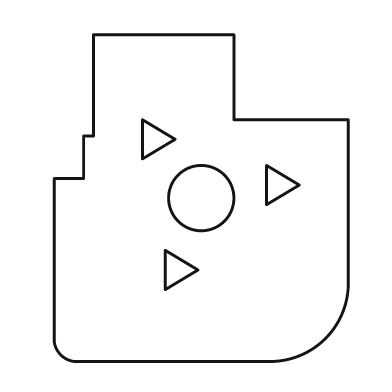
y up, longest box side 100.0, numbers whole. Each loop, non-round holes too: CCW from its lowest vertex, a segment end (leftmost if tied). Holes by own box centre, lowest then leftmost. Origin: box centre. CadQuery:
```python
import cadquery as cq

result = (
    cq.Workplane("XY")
    .moveTo(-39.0, -50.0)
    .lineTo(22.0, -50.0)
    .threePointArc((38.0, -43.0), (45.0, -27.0))
    .lineTo(45.0, 24.0)
    .lineTo(10.0, 24.0)
    .lineTo(10.0, 50.0)
    .lineTo(-33.0, 50.0)
    .lineTo(-33.0, 19.0)
    .lineTo(-36.0, 19.0)
    .lineTo(-36.0, 6.0)
    .lineTo(-45.0, 6.0)
    .lineTo(-45.0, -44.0)
    .threePointArc((-43.0, -48.0), (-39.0, -50.0))
    .close()
    .moveTo(-11.0, -28.0)
    .lineTo(-1.0, -22.0)
    .lineTo(-11.0, -16.0)
    .close()
    .moveTo(0.0, 0.0)
    .circle(10.0)
    .moveTo(20.0, -2.0)
    .lineTo(30.0, 4.0)
    .lineTo(20.0, 10.0)
    .close()
    .moveTo(-18.0, 12.0)
    .lineTo(-8.0, 18.0)
    .lineTo(-18.0, 24.0)
    .close()
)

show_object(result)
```